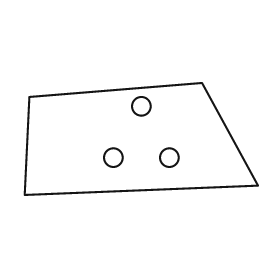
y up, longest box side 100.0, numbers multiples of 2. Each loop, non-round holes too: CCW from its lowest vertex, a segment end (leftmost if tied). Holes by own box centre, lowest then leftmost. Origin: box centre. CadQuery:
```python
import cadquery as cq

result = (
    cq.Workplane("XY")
    .moveTo(-50.0, -24.0)
    .lineTo(50.0, -20.0)
    .lineTo(26.0, 24.0)
    .lineTo(-48.0, 18.0)
    .close()
    .moveTo(-12.0, -8.0)
    .circle(4.0)
    .moveTo(12.0, -8.0)
    .circle(4.0)
    .moveTo(0.0, 14.0)
    .circle(4.0)
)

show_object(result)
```